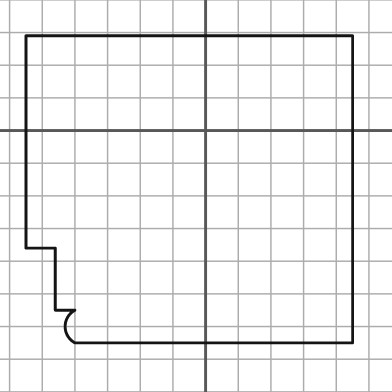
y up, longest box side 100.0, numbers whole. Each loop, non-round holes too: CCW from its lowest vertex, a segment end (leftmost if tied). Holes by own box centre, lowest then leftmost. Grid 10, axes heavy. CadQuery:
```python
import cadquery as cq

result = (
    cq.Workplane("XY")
    .moveTo(-40.0, -65.0)
    .lineTo(45.0, -65.0)
    .lineTo(45.0, 29.0)
    .lineTo(-55.0, 29.0)
    .lineTo(-55.0, -36.0)
    .lineTo(-46.0, -36.0)
    .lineTo(-46.0, -55.0)
    .lineTo(-40.0, -55.0)
    .threePointArc((-43.0, -60.0), (-40.0, -65.0))
    .close()
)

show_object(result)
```